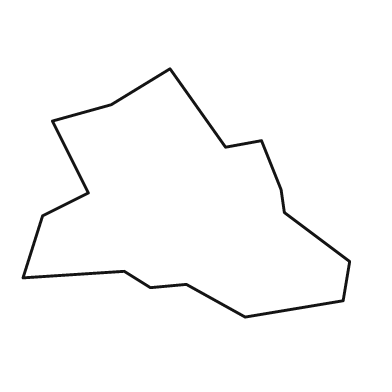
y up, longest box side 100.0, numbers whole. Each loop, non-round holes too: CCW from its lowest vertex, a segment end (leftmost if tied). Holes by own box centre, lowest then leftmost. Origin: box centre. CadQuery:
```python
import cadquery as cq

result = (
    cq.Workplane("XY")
    .moveTo(18.0, -38.0)
    .lineTo(48.0, -33.0)
    .lineTo(50.0, -21.0)
    .lineTo(30.0, -6.0)
    .lineTo(29.0, 1.0)
    .lineTo(23.0, 16.0)
    .lineTo(12.0, 14.0)
    .lineTo(-5.0, 38.0)
    .lineTo(-23.0, 27.0)
    .lineTo(-41.0, 22.0)
    .lineTo(-30.0, 0.0)
    .lineTo(-44.0, -7.0)
    .lineTo(-50.0, -26.0)
    .lineTo(-19.0, -24.0)
    .lineTo(-11.0, -29.0)
    .lineTo(0.0, -28.0)
    .close()
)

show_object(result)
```